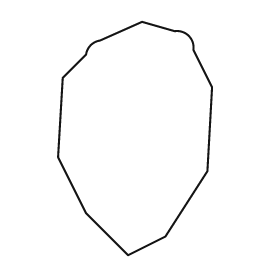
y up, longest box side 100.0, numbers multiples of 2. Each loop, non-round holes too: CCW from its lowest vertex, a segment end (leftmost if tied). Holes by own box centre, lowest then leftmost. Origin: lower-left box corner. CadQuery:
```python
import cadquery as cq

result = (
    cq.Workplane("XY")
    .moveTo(30.0, 0.0)
    .lineTo(46.0, 8.0)
    .lineTo(64.0, 36.0)
    .lineTo(66.0, 72.0)
    .lineTo(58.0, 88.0)
    .threePointArc((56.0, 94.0), (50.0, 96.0))
    .lineTo(36.0, 100.0)
    .lineTo(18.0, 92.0)
    .threePointArc((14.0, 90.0), (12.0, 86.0))
    .lineTo(2.0, 76.0)
    .lineTo(0.0, 42.0)
    .lineTo(12.0, 18.0)
    .close()
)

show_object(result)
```